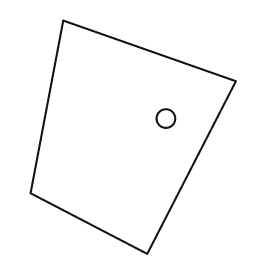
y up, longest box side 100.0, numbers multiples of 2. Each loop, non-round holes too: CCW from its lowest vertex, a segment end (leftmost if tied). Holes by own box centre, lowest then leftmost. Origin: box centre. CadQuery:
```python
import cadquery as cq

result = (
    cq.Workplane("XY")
    .moveTo(6.0, -50.0)
    .lineTo(44.0, 24.0)
    .lineTo(-30.0, 50.0)
    .lineTo(-44.0, -24.0)
    .close()
    .moveTo(14.0, 8.0)
    .circle(4.0)
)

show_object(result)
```